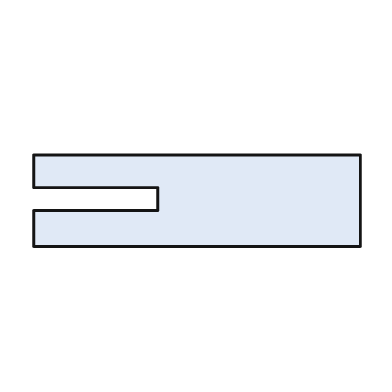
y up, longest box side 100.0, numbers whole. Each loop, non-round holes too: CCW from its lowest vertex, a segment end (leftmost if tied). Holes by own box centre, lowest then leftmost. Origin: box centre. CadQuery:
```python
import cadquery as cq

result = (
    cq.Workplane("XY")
    .moveTo(-50.0, -14.0)
    .lineTo(50.0, -14.0)
    .lineTo(50.0, 14.0)
    .lineTo(-50.0, 14.0)
    .lineTo(-50.0, 4.0)
    .lineTo(-12.0, 4.0)
    .lineTo(-12.0, -3.0)
    .lineTo(-50.0, -3.0)
    .close()
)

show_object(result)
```